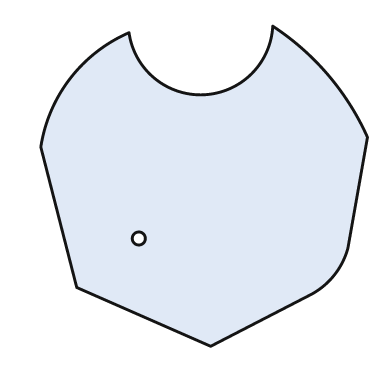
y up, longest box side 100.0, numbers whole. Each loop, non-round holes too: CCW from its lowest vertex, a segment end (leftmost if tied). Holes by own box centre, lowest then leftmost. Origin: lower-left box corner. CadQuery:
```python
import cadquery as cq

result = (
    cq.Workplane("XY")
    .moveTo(52.0, 0.0)
    .lineTo(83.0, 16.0)
    .threePointArc((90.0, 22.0), (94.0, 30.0))
    .lineTo(100.0, 64.0)
    .threePointArc((88.0, 83.0), (71.0, 98.0))
    .threePointArc((50.0, 77.0), (27.0, 96.0))
    .threePointArc((9.0, 82.0), (0.0, 61.0))
    .lineTo(11.0, 18.0)
    .close()
    .moveTo(30.0, 33.0)
    .circle(2.0)
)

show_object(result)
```